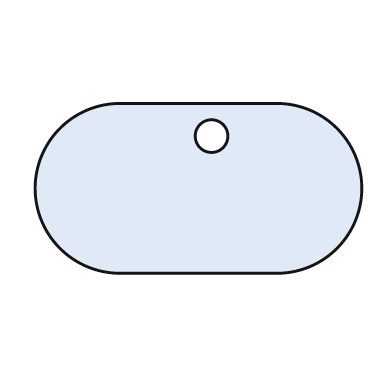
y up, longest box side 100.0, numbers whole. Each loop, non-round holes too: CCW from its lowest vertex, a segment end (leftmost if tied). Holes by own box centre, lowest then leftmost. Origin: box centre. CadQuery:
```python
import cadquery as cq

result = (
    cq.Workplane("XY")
    .moveTo(-24.0, -26.0)
    .lineTo(24.0, -26.0)
    .threePointArc((50.0, 0.0), (24.0, 26.0))
    .lineTo(-24.0, 26.0)
    .threePointArc((-50.0, 0.0), (-24.0, -26.0))
    .close()
    .moveTo(4.0, 16.0)
    .circle(5.0)
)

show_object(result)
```